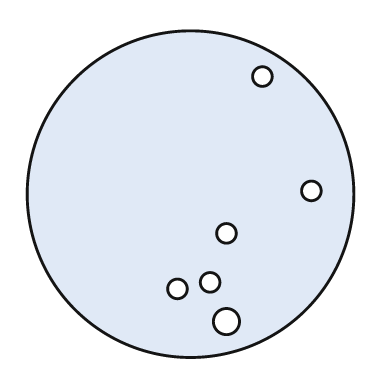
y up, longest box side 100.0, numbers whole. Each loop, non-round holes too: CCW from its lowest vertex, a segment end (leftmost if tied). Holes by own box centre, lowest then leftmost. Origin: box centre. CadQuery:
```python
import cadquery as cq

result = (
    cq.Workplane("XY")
    .moveTo(0.0, 0.0)
    .circle(50.0)
    .moveTo(11.0, -39.0)
    .circle(4.0)
    .moveTo(-4.0, -29.0)
    .circle(3.0)
    .moveTo(6.0, -27.0)
    .circle(3.0)
    .moveTo(11.0, -12.0)
    .circle(3.0)
    .moveTo(37.0, 1.0)
    .circle(3.0)
    .moveTo(22.0, 36.0)
    .circle(3.0)
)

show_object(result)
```